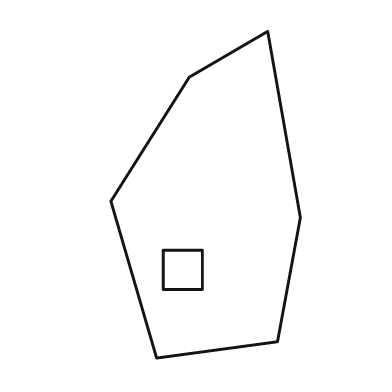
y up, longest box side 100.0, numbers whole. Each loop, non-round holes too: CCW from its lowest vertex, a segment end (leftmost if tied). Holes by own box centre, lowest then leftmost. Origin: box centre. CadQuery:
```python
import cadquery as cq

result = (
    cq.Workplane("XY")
    .moveTo(-15.0, -50.0)
    .lineTo(22.0, -45.0)
    .lineTo(29.0, -7.0)
    .lineTo(19.0, 50.0)
    .lineTo(-5.0, 36.0)
    .lineTo(-29.0, -2.0)
    .close()
    .moveTo(-13.0, -29.0)
    .lineTo(-1.0, -29.0)
    .lineTo(-1.0, -17.0)
    .lineTo(-13.0, -17.0)
    .close()
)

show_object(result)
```